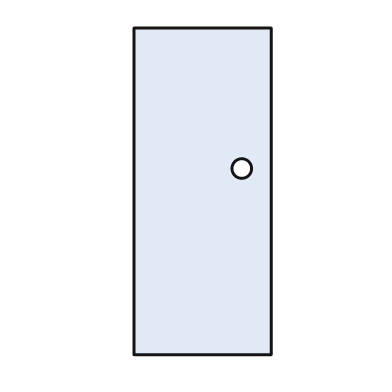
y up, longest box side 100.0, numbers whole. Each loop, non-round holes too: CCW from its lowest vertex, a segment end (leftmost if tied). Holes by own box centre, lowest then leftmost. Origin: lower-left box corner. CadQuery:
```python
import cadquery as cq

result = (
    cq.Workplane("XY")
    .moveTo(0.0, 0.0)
    .lineTo(42.0, 0.0)
    .lineTo(42.0, 100.0)
    .lineTo(0.0, 100.0)
    .close()
    .moveTo(33.0, 57.0)
    .circle(3.0)
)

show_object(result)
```